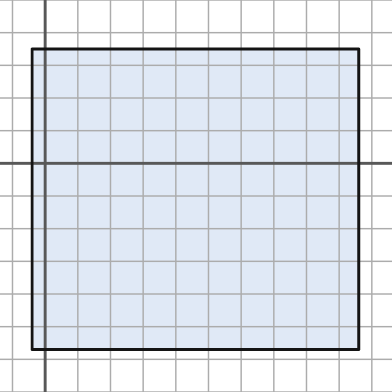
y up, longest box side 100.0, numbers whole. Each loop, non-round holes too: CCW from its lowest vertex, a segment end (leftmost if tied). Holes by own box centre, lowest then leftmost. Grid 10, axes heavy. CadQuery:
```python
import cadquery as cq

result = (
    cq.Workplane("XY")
    .moveTo(-4.0, -57.0)
    .lineTo(96.0, -57.0)
    .lineTo(96.0, 35.0)
    .lineTo(-4.0, 35.0)
    .close()
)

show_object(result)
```